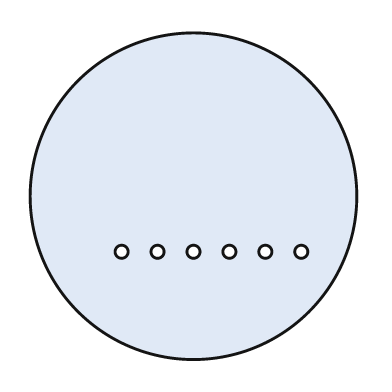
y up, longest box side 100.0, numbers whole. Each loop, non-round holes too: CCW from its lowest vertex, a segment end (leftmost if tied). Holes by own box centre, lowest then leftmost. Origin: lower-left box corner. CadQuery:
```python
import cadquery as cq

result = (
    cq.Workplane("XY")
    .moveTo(50.0, 50.0)
    .circle(50.0)
    .moveTo(28.0, 33.0)
    .circle(2.0)
    .moveTo(39.0, 33.0)
    .circle(2.0)
    .moveTo(50.0, 33.0)
    .circle(2.0)
    .moveTo(61.0, 33.0)
    .circle(2.0)
    .moveTo(72.0, 33.0)
    .circle(2.0)
    .moveTo(83.0, 33.0)
    .circle(2.0)
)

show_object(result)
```